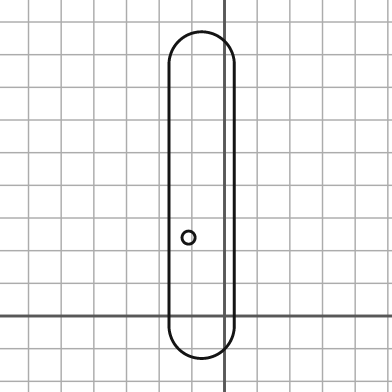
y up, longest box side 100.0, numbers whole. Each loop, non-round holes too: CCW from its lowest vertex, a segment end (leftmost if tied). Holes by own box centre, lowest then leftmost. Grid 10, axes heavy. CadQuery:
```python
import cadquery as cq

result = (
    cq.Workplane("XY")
    .moveTo(-17.0, -3.0)
    .threePointArc((-7.0, -13.0), (3.0, -3.0))
    .lineTo(3.0, 77.0)
    .threePointArc((-7.0, 87.0), (-17.0, 77.0))
    .close()
    .moveTo(-11.0, 24.0)
    .circle(2.0)
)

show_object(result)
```